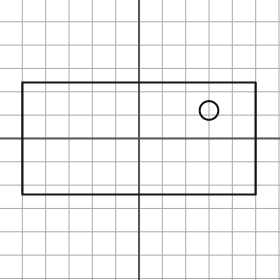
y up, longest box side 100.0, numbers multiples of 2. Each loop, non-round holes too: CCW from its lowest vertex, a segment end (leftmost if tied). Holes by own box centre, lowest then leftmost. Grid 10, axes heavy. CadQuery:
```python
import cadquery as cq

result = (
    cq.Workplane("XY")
    .moveTo(-50.0, -24.0)
    .lineTo(50.0, -24.0)
    .lineTo(50.0, 24.0)
    .lineTo(-50.0, 24.0)
    .close()
    .moveTo(30.0, 12.0)
    .circle(4.0)
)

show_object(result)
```